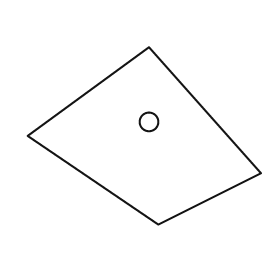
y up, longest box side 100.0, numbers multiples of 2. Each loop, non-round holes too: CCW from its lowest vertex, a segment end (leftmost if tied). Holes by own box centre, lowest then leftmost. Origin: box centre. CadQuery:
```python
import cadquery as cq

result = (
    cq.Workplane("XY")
    .moveTo(6.0, -38.0)
    .lineTo(50.0, -16.0)
    .lineTo(2.0, 38.0)
    .lineTo(-50.0, 0.0)
    .close()
    .moveTo(2.0, 6.0)
    .circle(4.0)
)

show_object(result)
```